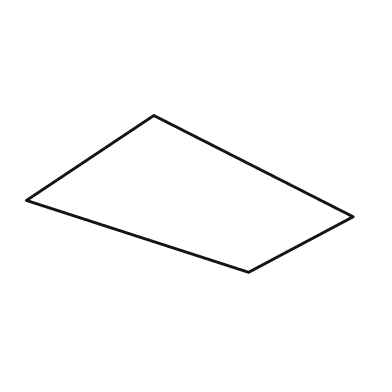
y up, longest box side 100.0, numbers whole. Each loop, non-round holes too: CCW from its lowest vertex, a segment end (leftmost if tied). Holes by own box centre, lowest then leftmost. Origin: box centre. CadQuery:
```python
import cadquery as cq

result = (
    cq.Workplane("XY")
    .moveTo(18.0, -24.0)
    .lineTo(50.0, -7.0)
    .lineTo(-11.0, 24.0)
    .lineTo(-50.0, -2.0)
    .close()
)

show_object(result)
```